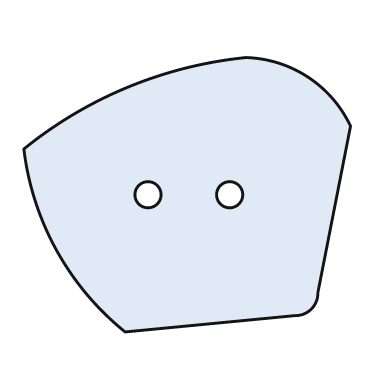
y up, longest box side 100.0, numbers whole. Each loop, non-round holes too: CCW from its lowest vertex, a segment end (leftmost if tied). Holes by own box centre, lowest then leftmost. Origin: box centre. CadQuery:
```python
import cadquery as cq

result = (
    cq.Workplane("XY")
    .moveTo(-19.0, -42.0)
    .lineTo(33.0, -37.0)
    .threePointArc((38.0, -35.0), (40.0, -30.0))
    .lineTo(50.0, 21.0)
    .threePointArc((37.0, 36.0), (18.0, 42.0))
    .threePointArc((-18.0, 33.0), (-50.0, 14.0))
    .threePointArc((-40.0, -17.0), (-19.0, -42.0))
    .close()
    .moveTo(-12.0, 0.0)
    .circle(4.0)
    .moveTo(13.0, 0.0)
    .circle(4.0)
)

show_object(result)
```